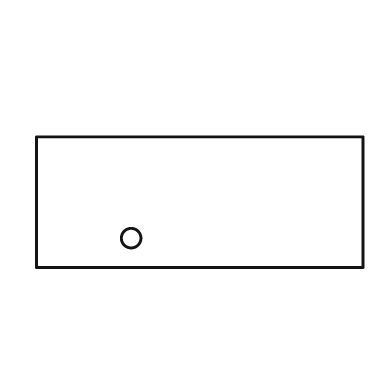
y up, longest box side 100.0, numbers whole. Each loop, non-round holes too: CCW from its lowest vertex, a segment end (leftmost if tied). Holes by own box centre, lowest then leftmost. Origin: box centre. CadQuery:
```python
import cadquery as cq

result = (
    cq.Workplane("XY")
    .moveTo(-50.0, -20.0)
    .lineTo(50.0, -20.0)
    .lineTo(50.0, 20.0)
    .lineTo(-50.0, 20.0)
    .close()
    .moveTo(-21.0, -11.0)
    .circle(3.0)
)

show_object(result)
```